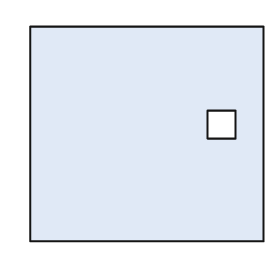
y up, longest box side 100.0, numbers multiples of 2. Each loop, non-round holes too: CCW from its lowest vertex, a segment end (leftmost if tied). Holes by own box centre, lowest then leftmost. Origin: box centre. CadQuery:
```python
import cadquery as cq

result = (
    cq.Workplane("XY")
    .moveTo(-50.0, -46.0)
    .lineTo(50.0, -46.0)
    .lineTo(50.0, 46.0)
    .lineTo(-50.0, 46.0)
    .close()
    .moveTo(26.0, -2.0)
    .lineTo(38.0, -2.0)
    .lineTo(38.0, 10.0)
    .lineTo(26.0, 10.0)
    .close()
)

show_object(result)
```